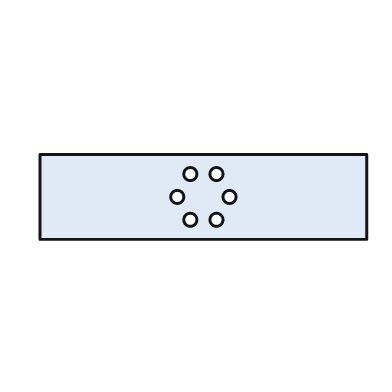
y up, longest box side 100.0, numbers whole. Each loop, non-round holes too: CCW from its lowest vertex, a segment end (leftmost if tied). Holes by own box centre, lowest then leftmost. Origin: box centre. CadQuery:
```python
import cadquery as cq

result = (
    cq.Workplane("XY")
    .moveTo(-50.0, -13.0)
    .lineTo(50.0, -13.0)
    .lineTo(50.0, 13.0)
    .lineTo(-50.0, 13.0)
    .close()
    .moveTo(-4.0, -7.0)
    .circle(2.0)
    .moveTo(4.0, -7.0)
    .circle(2.0)
    .moveTo(-8.0, 0.0)
    .circle(2.0)
    .moveTo(8.0, 0.0)
    .circle(2.0)
    .moveTo(-4.0, 7.0)
    .circle(2.0)
    .moveTo(4.0, 7.0)
    .circle(2.0)
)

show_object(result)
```